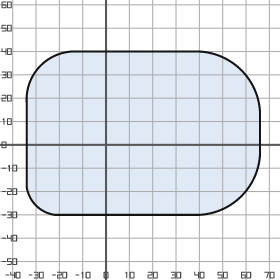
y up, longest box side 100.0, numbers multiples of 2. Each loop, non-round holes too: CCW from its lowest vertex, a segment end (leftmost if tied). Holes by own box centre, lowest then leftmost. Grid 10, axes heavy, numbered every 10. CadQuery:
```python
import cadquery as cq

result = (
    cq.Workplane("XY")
    .moveTo(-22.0, -30.0)
    .lineTo(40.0, -30.0)
    .threePointArc((58.0, -22.0), (66.0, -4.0))
    .lineTo(66.0, 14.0)
    .threePointArc((58.0, 32.0), (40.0, 40.0))
    .lineTo(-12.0, 40.0)
    .threePointArc((-28.0, 34.0), (-34.0, 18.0))
    .lineTo(-34.0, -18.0)
    .threePointArc((-30.0, -26.0), (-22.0, -30.0))
    .close()
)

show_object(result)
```